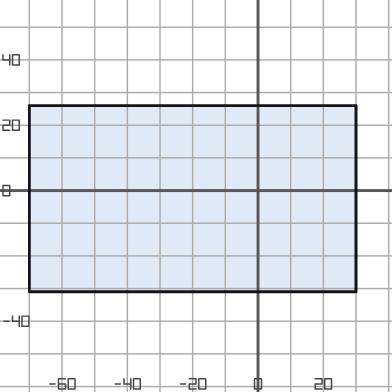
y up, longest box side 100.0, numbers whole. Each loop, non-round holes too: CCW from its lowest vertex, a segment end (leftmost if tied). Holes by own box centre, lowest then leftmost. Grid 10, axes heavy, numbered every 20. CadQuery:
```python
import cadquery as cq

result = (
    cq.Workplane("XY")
    .moveTo(-70.0, -31.0)
    .lineTo(30.0, -31.0)
    .lineTo(30.0, 26.0)
    .lineTo(-70.0, 26.0)
    .close()
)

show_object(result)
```